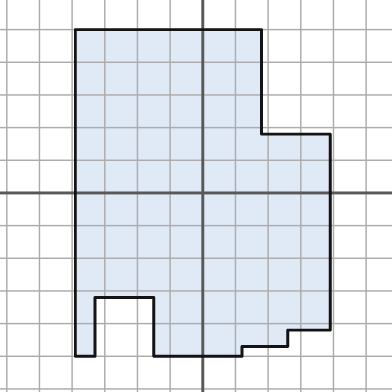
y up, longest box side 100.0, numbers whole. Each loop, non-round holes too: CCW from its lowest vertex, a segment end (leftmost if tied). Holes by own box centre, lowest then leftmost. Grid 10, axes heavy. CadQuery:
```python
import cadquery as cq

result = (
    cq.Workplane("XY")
    .moveTo(-39.0, -50.0)
    .lineTo(-33.0, -50.0)
    .lineTo(-33.0, -32.0)
    .lineTo(-15.0, -32.0)
    .lineTo(-15.0, -50.0)
    .lineTo(12.0, -50.0)
    .lineTo(12.0, -47.0)
    .lineTo(26.0, -47.0)
    .lineTo(26.0, -42.0)
    .lineTo(39.0, -42.0)
    .lineTo(39.0, 18.0)
    .lineTo(18.0, 18.0)
    .lineTo(18.0, 50.0)
    .lineTo(-39.0, 50.0)
    .close()
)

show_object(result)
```